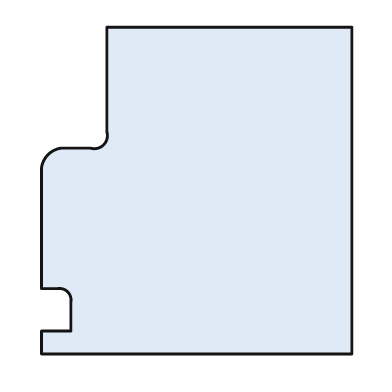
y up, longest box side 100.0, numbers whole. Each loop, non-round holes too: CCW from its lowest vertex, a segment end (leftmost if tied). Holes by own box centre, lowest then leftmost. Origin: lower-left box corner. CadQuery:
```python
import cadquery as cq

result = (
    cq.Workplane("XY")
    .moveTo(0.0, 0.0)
    .lineTo(95.0, 0.0)
    .lineTo(95.0, 100.0)
    .lineTo(20.0, 100.0)
    .lineTo(20.0, 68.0)
    .threePointArc((19.0, 64.0), (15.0, 63.0))
    .lineTo(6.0, 63.0)
    .threePointArc((2.0, 61.0), (0.0, 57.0))
    .lineTo(0.0, 20.0)
    .lineTo(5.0, 20.0)
    .threePointArc((8.0, 19.0), (9.0, 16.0))
    .lineTo(9.0, 7.0)
    .lineTo(0.0, 7.0)
    .close()
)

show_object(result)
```